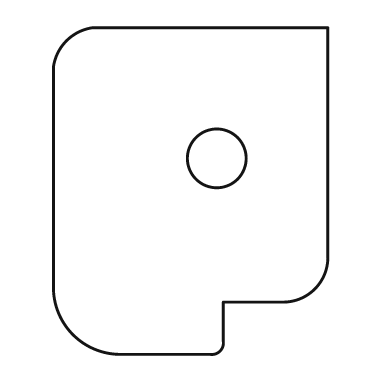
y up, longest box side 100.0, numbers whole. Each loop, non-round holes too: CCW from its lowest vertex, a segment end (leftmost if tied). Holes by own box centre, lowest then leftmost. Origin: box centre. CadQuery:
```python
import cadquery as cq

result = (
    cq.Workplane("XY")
    .moveTo(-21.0, -50.0)
    .lineTo(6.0, -50.0)
    .threePointArc((9.0, -49.0), (10.0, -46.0))
    .lineTo(10.0, -34.0)
    .lineTo(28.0, -34.0)
    .threePointArc((38.0, -30.0), (42.0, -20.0))
    .lineTo(42.0, 50.0)
    .lineTo(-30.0, 50.0)
    .threePointArc((-38.0, 46.0), (-42.0, 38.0))
    .lineTo(-42.0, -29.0)
    .threePointArc((-36.0, -44.0), (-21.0, -50.0))
    .close()
    .moveTo(8.0, 10.0)
    .circle(9.0)
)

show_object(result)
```